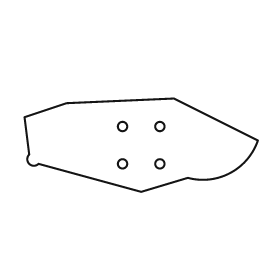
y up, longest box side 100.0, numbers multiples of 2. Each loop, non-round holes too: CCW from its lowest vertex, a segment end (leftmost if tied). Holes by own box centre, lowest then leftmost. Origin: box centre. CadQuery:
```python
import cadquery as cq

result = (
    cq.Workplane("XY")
    .moveTo(0.0, -20.0)
    .lineTo(20.0, -14.0)
    .threePointArc((38.0, -12.0), (50.0, 2.0))
    .lineTo(14.0, 20.0)
    .lineTo(-32.0, 18.0)
    .lineTo(-50.0, 12.0)
    .lineTo(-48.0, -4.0)
    .threePointArc((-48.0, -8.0), (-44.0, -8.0))
    .close()
    .moveTo(-8.0, -8.0)
    .circle(2.0)
    .moveTo(8.0, -8.0)
    .circle(2.0)
    .moveTo(-8.0, 8.0)
    .circle(2.0)
    .moveTo(8.0, 8.0)
    .circle(2.0)
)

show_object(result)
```